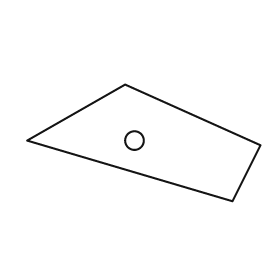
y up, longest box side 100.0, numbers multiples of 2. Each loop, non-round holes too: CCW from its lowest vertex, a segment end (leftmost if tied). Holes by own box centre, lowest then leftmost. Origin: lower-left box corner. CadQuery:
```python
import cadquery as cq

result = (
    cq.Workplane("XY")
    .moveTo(88.0, 0.0)
    .lineTo(100.0, 24.0)
    .lineTo(42.0, 50.0)
    .lineTo(0.0, 26.0)
    .close()
    .moveTo(46.0, 26.0)
    .circle(4.0)
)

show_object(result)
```